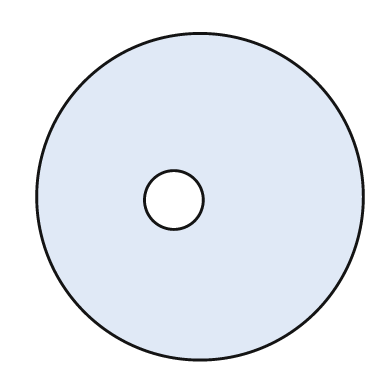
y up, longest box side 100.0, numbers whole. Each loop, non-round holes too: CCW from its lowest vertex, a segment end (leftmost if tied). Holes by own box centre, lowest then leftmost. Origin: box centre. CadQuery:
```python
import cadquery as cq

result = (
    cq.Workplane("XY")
    .moveTo(0.0, 0.0)
    .circle(50.0)
    .moveTo(-8.0, -1.0)
    .circle(9.0)
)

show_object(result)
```